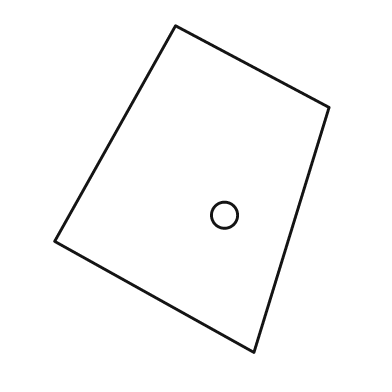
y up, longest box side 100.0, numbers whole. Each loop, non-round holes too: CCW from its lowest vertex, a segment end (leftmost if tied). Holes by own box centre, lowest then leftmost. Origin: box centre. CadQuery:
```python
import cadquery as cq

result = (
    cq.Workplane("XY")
    .moveTo(19.0, -50.0)
    .lineTo(42.0, 25.0)
    .lineTo(-5.0, 50.0)
    .lineTo(-42.0, -16.0)
    .close()
    .moveTo(10.0, -8.0)
    .circle(4.0)
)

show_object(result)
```